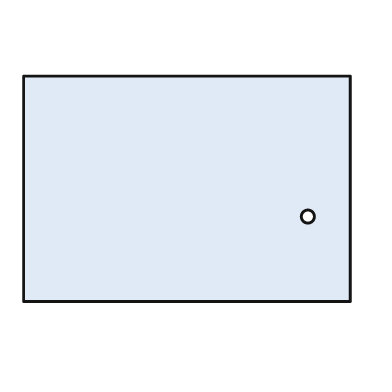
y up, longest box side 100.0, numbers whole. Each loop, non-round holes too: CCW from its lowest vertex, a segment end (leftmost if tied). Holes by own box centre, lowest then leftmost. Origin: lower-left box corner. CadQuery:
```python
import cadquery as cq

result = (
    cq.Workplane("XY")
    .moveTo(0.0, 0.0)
    .lineTo(100.0, 0.0)
    .lineTo(100.0, 69.0)
    .lineTo(0.0, 69.0)
    .close()
    .moveTo(87.0, 26.0)
    .circle(2.0)
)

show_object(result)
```